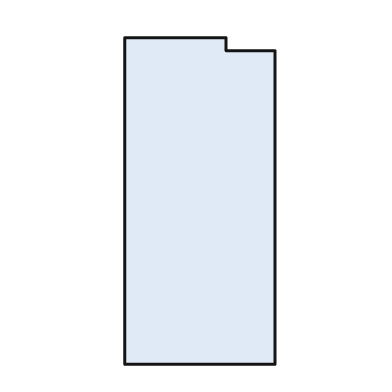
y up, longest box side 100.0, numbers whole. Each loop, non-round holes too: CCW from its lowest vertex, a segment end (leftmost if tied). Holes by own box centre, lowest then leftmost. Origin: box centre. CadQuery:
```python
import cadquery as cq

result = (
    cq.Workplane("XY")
    .moveTo(-23.0, -50.0)
    .lineTo(23.0, -50.0)
    .lineTo(23.0, 46.0)
    .lineTo(8.0, 46.0)
    .lineTo(8.0, 50.0)
    .lineTo(-23.0, 50.0)
    .close()
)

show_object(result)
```